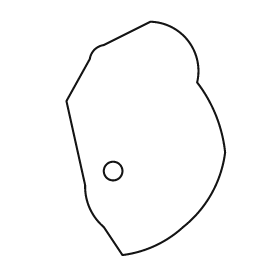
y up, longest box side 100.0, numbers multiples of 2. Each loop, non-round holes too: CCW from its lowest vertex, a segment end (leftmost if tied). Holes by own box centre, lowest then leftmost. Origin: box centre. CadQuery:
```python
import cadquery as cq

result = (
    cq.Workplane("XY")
    .moveTo(-10.0, -50.0)
    .threePointArc((4.0, -46.0), (16.0, -38.0))
    .threePointArc((28.0, -24.0), (34.0, -6.0))
    .threePointArc((30.0, 10.0), (22.0, 24.0))
    .threePointArc((18.0, 42.0), (2.0, 50.0))
    .lineTo(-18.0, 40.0)
    .threePointArc((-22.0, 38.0), (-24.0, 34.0))
    .lineTo(-34.0, 16.0)
    .lineTo(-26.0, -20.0)
    .threePointArc((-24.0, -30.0), (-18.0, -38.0))
    .close()
    .moveTo(-14.0, -14.0)
    .circle(4.0)
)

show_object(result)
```